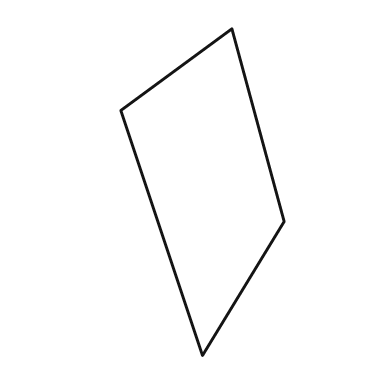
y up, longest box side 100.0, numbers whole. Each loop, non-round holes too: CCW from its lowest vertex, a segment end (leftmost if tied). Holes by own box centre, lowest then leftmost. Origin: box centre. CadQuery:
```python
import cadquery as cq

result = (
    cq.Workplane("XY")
    .moveTo(0.0, -50.0)
    .lineTo(25.0, -9.0)
    .lineTo(9.0, 50.0)
    .lineTo(-25.0, 25.0)
    .close()
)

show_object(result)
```